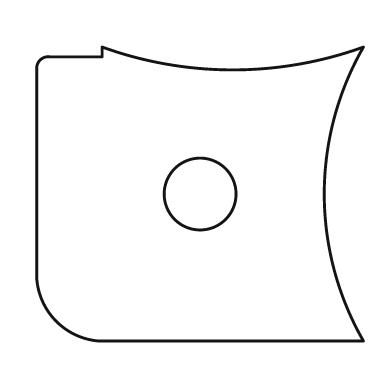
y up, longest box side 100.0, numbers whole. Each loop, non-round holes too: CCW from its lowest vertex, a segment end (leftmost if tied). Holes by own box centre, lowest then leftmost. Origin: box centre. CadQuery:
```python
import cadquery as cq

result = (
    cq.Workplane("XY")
    .moveTo(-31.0, -45.0)
    .lineTo(50.0, -45.0)
    .threePointArc((38.0, 0.0), (50.0, 45.0))
    .threePointArc((10.0, 38.0), (-30.0, 45.0))
    .lineTo(-30.0, 42.0)
    .lineTo(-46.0, 42.0)
    .threePointArc((-49.0, 41.0), (-50.0, 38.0))
    .lineTo(-50.0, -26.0)
    .threePointArc((-44.0, -39.0), (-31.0, -45.0))
    .close()
    .moveTo(0.0, 0.0)
    .circle(11.0)
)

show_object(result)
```